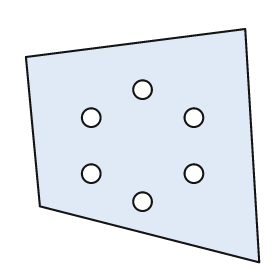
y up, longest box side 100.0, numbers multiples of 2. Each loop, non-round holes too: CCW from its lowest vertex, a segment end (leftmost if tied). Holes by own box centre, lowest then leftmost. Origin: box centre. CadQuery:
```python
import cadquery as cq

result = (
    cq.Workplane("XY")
    .moveTo(50.0, -50.0)
    .lineTo(44.0, 50.0)
    .lineTo(-50.0, 38.0)
    .lineTo(-44.0, -26.0)
    .close()
    .moveTo(0.0, -24.0)
    .circle(4.0)
    .moveTo(-22.0, -12.0)
    .circle(4.0)
    .moveTo(22.0, -12.0)
    .circle(4.0)
    .moveTo(-22.0, 12.0)
    .circle(4.0)
    .moveTo(22.0, 12.0)
    .circle(4.0)
    .moveTo(0.0, 24.0)
    .circle(4.0)
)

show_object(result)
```